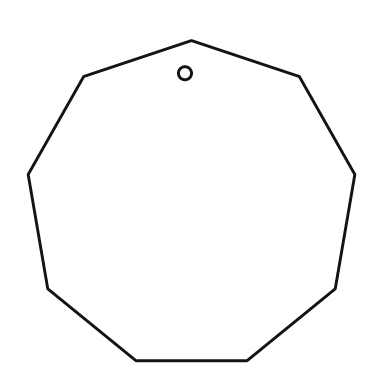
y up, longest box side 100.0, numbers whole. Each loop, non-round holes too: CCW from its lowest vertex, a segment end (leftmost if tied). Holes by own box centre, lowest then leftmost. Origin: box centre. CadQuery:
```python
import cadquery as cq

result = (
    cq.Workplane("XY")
    .moveTo(-17.0, -49.0)
    .lineTo(17.0, -49.0)
    .lineTo(44.0, -27.0)
    .lineTo(50.0, 8.0)
    .lineTo(33.0, 38.0)
    .lineTo(0.0, 49.0)
    .lineTo(-33.0, 38.0)
    .lineTo(-50.0, 8.0)
    .lineTo(-44.0, -27.0)
    .close()
    .moveTo(-2.0, 39.0)
    .circle(2.0)
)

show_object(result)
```